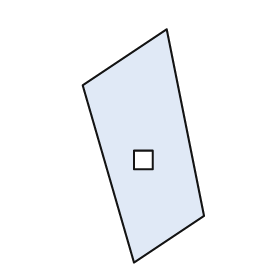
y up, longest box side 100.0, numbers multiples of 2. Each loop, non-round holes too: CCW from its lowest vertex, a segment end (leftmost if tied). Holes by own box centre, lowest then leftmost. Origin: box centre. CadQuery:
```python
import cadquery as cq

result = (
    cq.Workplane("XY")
    .moveTo(-4.0, -50.0)
    .lineTo(26.0, -30.0)
    .lineTo(10.0, 50.0)
    .lineTo(-26.0, 26.0)
    .close()
    .moveTo(-4.0, -10.0)
    .lineTo(4.0, -10.0)
    .lineTo(4.0, -2.0)
    .lineTo(-4.0, -2.0)
    .close()
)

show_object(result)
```